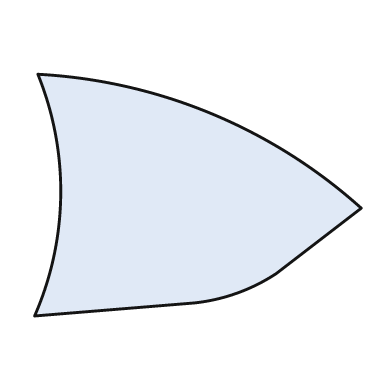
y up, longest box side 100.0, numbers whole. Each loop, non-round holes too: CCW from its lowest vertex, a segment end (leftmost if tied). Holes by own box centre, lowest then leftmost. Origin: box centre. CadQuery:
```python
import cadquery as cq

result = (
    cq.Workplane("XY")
    .moveTo(-50.0, -37.0)
    .lineTo(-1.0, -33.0)
    .threePointArc((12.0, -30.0), (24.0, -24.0))
    .lineTo(50.0, -4.0)
    .threePointArc((4.0, 25.0), (-49.0, 37.0))
    .threePointArc((-42.0, 0.0), (-50.0, -37.0))
    .close()
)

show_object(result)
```